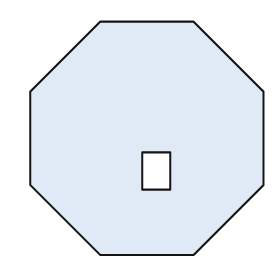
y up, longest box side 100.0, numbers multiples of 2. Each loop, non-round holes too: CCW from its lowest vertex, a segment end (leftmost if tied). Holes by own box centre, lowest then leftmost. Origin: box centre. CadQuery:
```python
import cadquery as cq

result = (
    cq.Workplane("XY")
    .moveTo(-20.0, -50.0)
    .lineTo(20.0, -50.0)
    .lineTo(50.0, -20.0)
    .lineTo(50.0, 20.0)
    .lineTo(20.0, 50.0)
    .lineTo(-20.0, 50.0)
    .lineTo(-50.0, 20.0)
    .lineTo(-50.0, -20.0)
    .close()
    .moveTo(-2.0, -22.0)
    .lineTo(10.0, -22.0)
    .lineTo(10.0, -6.0)
    .lineTo(-2.0, -6.0)
    .close()
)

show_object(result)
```